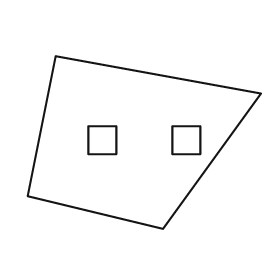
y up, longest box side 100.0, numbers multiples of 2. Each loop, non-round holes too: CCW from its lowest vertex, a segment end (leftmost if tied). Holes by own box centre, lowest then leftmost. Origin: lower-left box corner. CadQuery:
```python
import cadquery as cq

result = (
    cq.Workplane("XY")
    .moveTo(58.0, 0.0)
    .lineTo(100.0, 58.0)
    .lineTo(12.0, 74.0)
    .lineTo(0.0, 14.0)
    .close()
    .moveTo(26.0, 32.0)
    .lineTo(38.0, 32.0)
    .lineTo(38.0, 44.0)
    .lineTo(26.0, 44.0)
    .close()
    .moveTo(62.0, 32.0)
    .lineTo(74.0, 32.0)
    .lineTo(74.0, 44.0)
    .lineTo(62.0, 44.0)
    .close()
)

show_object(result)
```